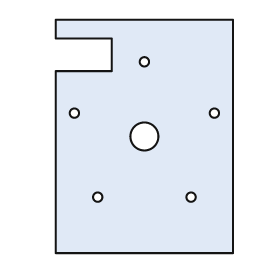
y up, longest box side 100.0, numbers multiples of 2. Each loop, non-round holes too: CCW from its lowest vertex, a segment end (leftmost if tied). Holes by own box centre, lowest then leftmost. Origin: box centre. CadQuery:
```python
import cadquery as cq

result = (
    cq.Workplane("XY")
    .moveTo(-38.0, -50.0)
    .lineTo(38.0, -50.0)
    .lineTo(38.0, 50.0)
    .lineTo(-38.0, 50.0)
    .lineTo(-38.0, 42.0)
    .lineTo(-14.0, 42.0)
    .lineTo(-14.0, 28.0)
    .lineTo(-38.0, 28.0)
    .close()
    .moveTo(-20.0, -26.0)
    .circle(2.0)
    .moveTo(20.0, -26.0)
    .circle(2.0)
    .moveTo(0.0, 0.0)
    .circle(6.0)
    .moveTo(-30.0, 10.0)
    .circle(2.0)
    .moveTo(30.0, 10.0)
    .circle(2.0)
    .moveTo(0.0, 32.0)
    .circle(2.0)
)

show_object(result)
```